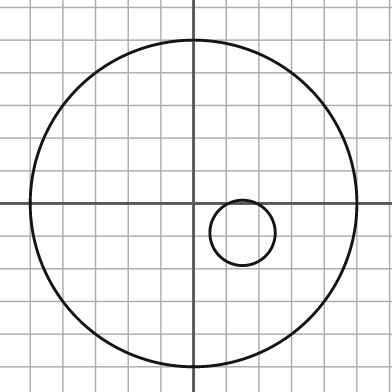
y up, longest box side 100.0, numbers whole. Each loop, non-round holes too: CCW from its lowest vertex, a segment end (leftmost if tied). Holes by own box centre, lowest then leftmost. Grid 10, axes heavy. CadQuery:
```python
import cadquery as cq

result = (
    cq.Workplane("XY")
    .moveTo(0.0, 0.0)
    .circle(50.0)
    .moveTo(15.0, -9.0)
    .circle(10.0)
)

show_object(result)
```